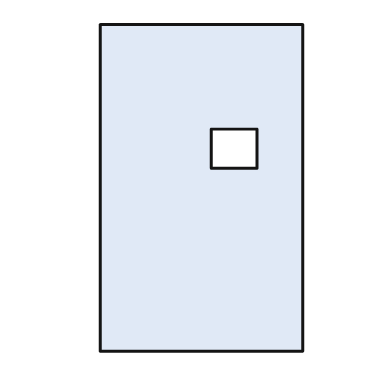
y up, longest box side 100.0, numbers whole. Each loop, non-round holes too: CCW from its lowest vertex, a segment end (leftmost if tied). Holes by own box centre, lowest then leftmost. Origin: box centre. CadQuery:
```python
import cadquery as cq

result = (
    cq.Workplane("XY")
    .moveTo(-31.0, -50.0)
    .lineTo(31.0, -50.0)
    .lineTo(31.0, 50.0)
    .lineTo(-31.0, 50.0)
    .close()
    .moveTo(3.0, 6.0)
    .lineTo(17.0, 6.0)
    .lineTo(17.0, 18.0)
    .lineTo(3.0, 18.0)
    .close()
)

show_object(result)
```